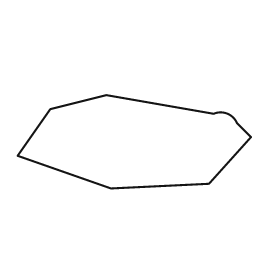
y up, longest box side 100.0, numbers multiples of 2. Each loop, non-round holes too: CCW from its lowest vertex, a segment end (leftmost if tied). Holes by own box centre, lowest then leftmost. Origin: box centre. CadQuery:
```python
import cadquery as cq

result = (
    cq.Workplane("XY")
    .moveTo(-10.0, -20.0)
    .lineTo(32.0, -18.0)
    .lineTo(50.0, 2.0)
    .lineTo(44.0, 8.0)
    .threePointArc((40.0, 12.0), (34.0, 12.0))
    .lineTo(-12.0, 20.0)
    .lineTo(-36.0, 14.0)
    .lineTo(-50.0, -6.0)
    .close()
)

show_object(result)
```